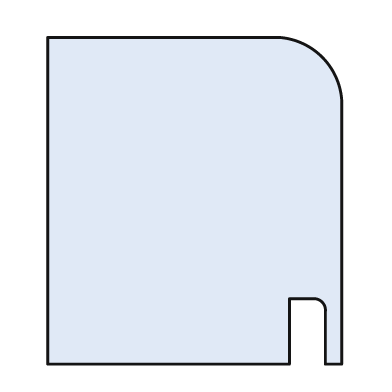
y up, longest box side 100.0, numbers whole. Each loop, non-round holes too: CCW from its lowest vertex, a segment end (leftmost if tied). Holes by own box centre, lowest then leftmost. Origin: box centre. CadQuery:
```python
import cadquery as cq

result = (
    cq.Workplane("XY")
    .moveTo(-45.0, -50.0)
    .lineTo(29.0, -50.0)
    .lineTo(29.0, -30.0)
    .lineTo(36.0, -30.0)
    .threePointArc((39.0, -31.0), (40.0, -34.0))
    .lineTo(40.0, -50.0)
    .lineTo(45.0, -50.0)
    .lineTo(45.0, 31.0)
    .threePointArc((39.0, 44.0), (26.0, 50.0))
    .lineTo(-45.0, 50.0)
    .close()
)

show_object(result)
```